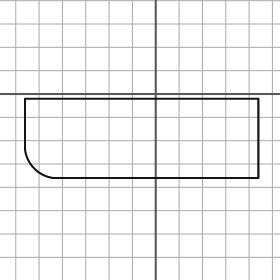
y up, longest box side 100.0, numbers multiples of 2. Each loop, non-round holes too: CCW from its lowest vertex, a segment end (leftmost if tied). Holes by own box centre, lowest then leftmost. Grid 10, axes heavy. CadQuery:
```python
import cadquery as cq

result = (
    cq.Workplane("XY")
    .moveTo(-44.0, -36.0)
    .lineTo(44.0, -36.0)
    .lineTo(44.0, -2.0)
    .lineTo(-56.0, -2.0)
    .lineTo(-56.0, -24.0)
    .threePointArc((-52.0, -32.0), (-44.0, -36.0))
    .close()
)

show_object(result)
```